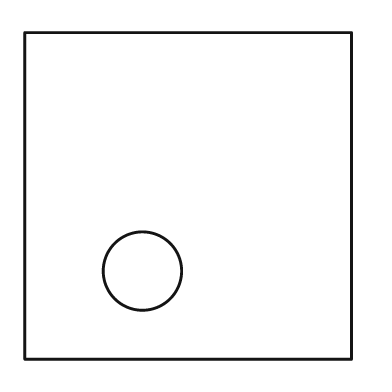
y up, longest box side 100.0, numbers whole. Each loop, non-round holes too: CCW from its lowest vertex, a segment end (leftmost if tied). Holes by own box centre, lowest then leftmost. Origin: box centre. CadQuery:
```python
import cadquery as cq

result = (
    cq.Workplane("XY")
    .moveTo(-50.0, -50.0)
    .lineTo(50.0, -50.0)
    .lineTo(50.0, 50.0)
    .lineTo(-50.0, 50.0)
    .close()
    .moveTo(-14.0, -23.0)
    .circle(12.0)
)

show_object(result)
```